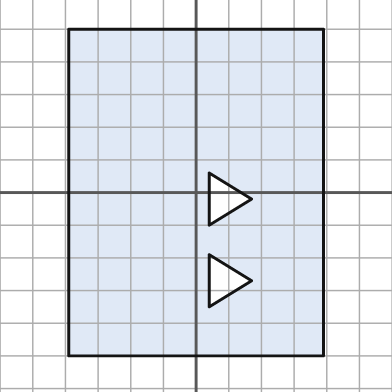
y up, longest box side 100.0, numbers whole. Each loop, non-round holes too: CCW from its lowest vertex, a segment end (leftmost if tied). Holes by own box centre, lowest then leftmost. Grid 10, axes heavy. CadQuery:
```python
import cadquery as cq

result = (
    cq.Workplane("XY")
    .moveTo(-39.0, -50.0)
    .lineTo(39.0, -50.0)
    .lineTo(39.0, 50.0)
    .lineTo(-39.0, 50.0)
    .close()
    .moveTo(4.0, -35.0)
    .lineTo(17.0, -27.0)
    .lineTo(4.0, -19.0)
    .close()
    .moveTo(4.0, -10.0)
    .lineTo(17.0, -2.0)
    .lineTo(4.0, 6.0)
    .close()
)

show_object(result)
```